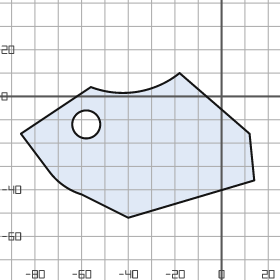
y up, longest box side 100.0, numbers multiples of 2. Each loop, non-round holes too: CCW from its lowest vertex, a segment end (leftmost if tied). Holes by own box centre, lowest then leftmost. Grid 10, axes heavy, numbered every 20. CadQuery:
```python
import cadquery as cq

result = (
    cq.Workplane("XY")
    .moveTo(-40.0, -52.0)
    .lineTo(14.0, -36.0)
    .lineTo(12.0, -16.0)
    .lineTo(-18.0, 10.0)
    .threePointArc((-36.0, 2.0), (-56.0, 4.0))
    .lineTo(-86.0, -16.0)
    .lineTo(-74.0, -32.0)
    .threePointArc((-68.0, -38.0), (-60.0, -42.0))
    .close()
    .moveTo(-58.0, -12.0)
    .circle(6.0)
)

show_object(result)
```